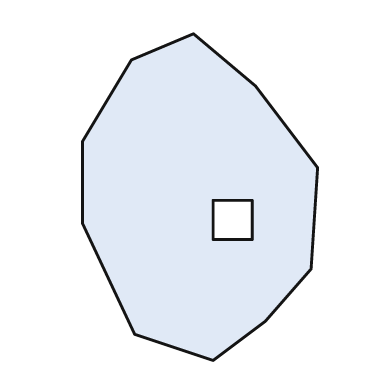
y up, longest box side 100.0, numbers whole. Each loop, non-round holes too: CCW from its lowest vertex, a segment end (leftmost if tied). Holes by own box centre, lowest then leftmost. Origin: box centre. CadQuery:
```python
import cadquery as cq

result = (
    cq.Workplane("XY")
    .moveTo(4.0, -50.0)
    .lineTo(20.0, -38.0)
    .lineTo(34.0, -22.0)
    .lineTo(36.0, 9.0)
    .lineTo(17.0, 34.0)
    .lineTo(-2.0, 50.0)
    .lineTo(-21.0, 42.0)
    .lineTo(-36.0, 17.0)
    .lineTo(-36.0, -8.0)
    .lineTo(-20.0, -42.0)
    .close()
    .moveTo(4.0, -13.0)
    .lineTo(16.0, -13.0)
    .lineTo(16.0, -1.0)
    .lineTo(4.0, -1.0)
    .close()
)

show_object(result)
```